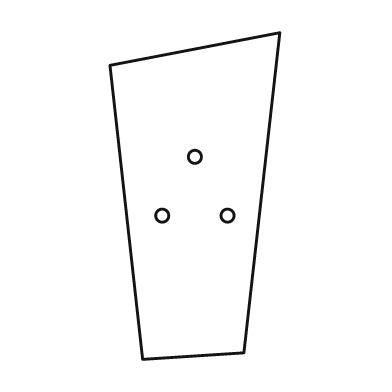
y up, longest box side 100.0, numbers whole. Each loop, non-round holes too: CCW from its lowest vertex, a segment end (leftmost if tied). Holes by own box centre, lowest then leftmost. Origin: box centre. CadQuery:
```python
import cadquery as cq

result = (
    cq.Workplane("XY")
    .moveTo(-16.0, -50.0)
    .lineTo(15.0, -48.0)
    .lineTo(26.0, 50.0)
    .lineTo(-26.0, 40.0)
    .close()
    .moveTo(-10.0, -6.0)
    .circle(2.0)
    .moveTo(10.0, -6.0)
    .circle(2.0)
    .moveTo(0.0, 12.0)
    .circle(2.0)
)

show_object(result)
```